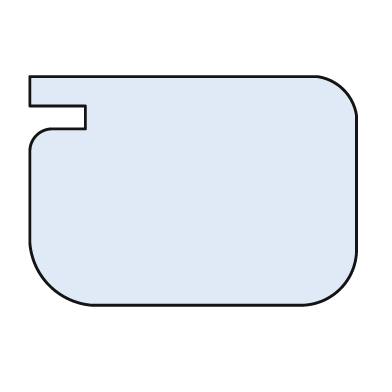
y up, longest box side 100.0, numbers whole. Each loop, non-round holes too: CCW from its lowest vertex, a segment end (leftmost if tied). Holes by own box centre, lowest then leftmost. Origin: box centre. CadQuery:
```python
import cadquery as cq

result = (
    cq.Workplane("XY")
    .moveTo(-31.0, -35.0)
    .lineTo(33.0, -35.0)
    .threePointArc((45.0, -30.0), (50.0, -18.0))
    .lineTo(50.0, 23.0)
    .threePointArc((46.0, 31.0), (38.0, 35.0))
    .lineTo(-50.0, 35.0)
    .lineTo(-50.0, 26.0)
    .lineTo(-33.0, 26.0)
    .lineTo(-33.0, 19.0)
    .lineTo(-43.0, 19.0)
    .threePointArc((-48.0, 17.0), (-50.0, 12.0))
    .lineTo(-50.0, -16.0)
    .threePointArc((-44.0, -29.0), (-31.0, -35.0))
    .close()
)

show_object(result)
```